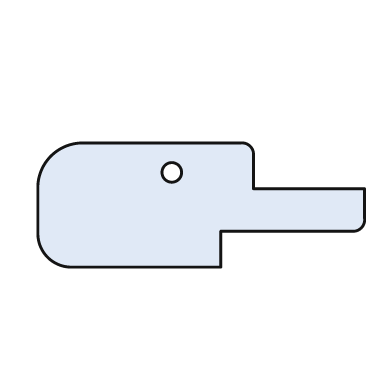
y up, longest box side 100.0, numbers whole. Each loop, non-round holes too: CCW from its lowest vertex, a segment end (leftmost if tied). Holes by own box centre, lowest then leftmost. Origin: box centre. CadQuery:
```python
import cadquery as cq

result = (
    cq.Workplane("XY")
    .moveTo(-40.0, -19.0)
    .lineTo(6.0, -19.0)
    .lineTo(6.0, -8.0)
    .lineTo(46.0, -8.0)
    .threePointArc((49.0, -7.0), (50.0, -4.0))
    .lineTo(50.0, 5.0)
    .lineTo(16.0, 5.0)
    .lineTo(16.0, 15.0)
    .threePointArc((15.0, 18.0), (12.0, 19.0))
    .lineTo(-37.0, 19.0)
    .threePointArc((-46.0, 15.0), (-50.0, 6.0))
    .lineTo(-50.0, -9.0)
    .threePointArc((-47.0, -16.0), (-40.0, -19.0))
    .close()
    .moveTo(-9.0, 10.0)
    .circle(3.0)
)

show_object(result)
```